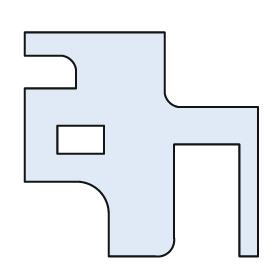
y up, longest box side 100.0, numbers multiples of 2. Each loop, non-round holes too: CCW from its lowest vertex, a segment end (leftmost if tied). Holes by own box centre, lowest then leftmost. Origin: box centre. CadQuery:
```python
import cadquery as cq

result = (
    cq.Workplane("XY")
    .moveTo(-14.0, -48.0)
    .lineTo(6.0, -48.0)
    .threePointArc((12.0, -46.0), (14.0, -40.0))
    .lineTo(14.0, 0.0)
    .lineTo(42.0, 0.0)
    .lineTo(42.0, -48.0)
    .lineTo(50.0, -48.0)
    .lineTo(50.0, 16.0)
    .lineTo(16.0, 16.0)
    .threePointArc((12.0, 18.0), (10.0, 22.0))
    .lineTo(10.0, 48.0)
    .lineTo(-50.0, 48.0)
    .lineTo(-50.0, 38.0)
    .lineTo(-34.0, 38.0)
    .threePointArc((-30.0, 36.0), (-28.0, 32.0))
    .lineTo(-28.0, 24.0)
    .lineTo(-50.0, 24.0)
    .lineTo(-50.0, -16.0)
    .lineTo(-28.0, -16.0)
    .threePointArc((-18.0, -20.0), (-14.0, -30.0))
    .close()
    .moveTo(-36.0, -4.0)
    .lineTo(-16.0, -4.0)
    .lineTo(-16.0, 8.0)
    .lineTo(-36.0, 8.0)
    .close()
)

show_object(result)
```